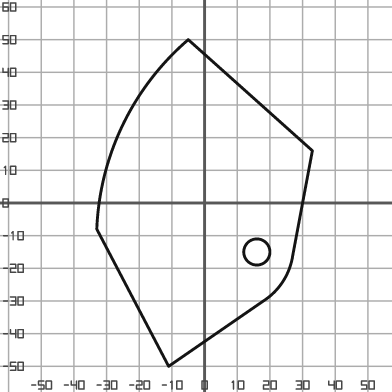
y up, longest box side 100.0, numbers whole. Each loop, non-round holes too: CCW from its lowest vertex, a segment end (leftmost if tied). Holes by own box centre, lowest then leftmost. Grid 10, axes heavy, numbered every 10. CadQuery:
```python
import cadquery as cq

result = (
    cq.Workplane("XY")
    .moveTo(-11.0, -50.0)
    .lineTo(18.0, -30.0)
    .threePointArc((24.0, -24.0), (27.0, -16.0))
    .lineTo(33.0, 16.0)
    .lineTo(-5.0, 50.0)
    .threePointArc((-25.0, 24.0), (-33.0, -8.0))
    .close()
    .moveTo(16.0, -15.0)
    .circle(4.0)
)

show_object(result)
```